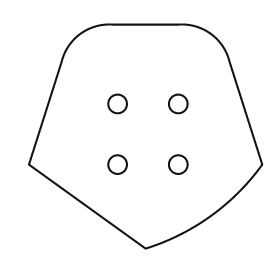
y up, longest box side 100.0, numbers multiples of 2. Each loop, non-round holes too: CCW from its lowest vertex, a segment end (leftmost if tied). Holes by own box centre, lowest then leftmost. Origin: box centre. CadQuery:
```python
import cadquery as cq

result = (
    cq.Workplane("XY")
    .moveTo(0.0, -48.0)
    .threePointArc((28.0, -34.0), (50.0, -12.0))
    .lineTo(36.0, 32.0)
    .threePointArc((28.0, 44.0), (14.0, 48.0))
    .lineTo(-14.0, 48.0)
    .threePointArc((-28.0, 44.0), (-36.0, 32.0))
    .lineTo(-50.0, -12.0)
    .close()
    .moveTo(-12.0, -12.0)
    .circle(4.0)
    .moveTo(14.0, -12.0)
    .circle(4.0)
    .moveTo(-12.0, 14.0)
    .circle(4.0)
    .moveTo(14.0, 14.0)
    .circle(4.0)
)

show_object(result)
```